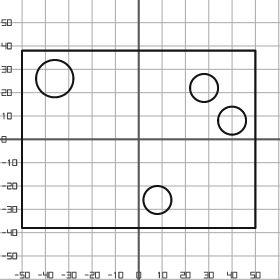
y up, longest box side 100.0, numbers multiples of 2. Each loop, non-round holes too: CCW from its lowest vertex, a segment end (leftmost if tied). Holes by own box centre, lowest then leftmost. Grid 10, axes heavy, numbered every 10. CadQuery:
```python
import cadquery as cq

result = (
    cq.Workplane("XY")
    .moveTo(-50.0, -38.0)
    .lineTo(50.0, -38.0)
    .lineTo(50.0, 38.0)
    .lineTo(-50.0, 38.0)
    .close()
    .moveTo(8.0, -26.0)
    .circle(6.0)
    .moveTo(40.0, 8.0)
    .circle(6.0)
    .moveTo(28.0, 22.0)
    .circle(6.0)
    .moveTo(-36.0, 26.0)
    .circle(8.0)
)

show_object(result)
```